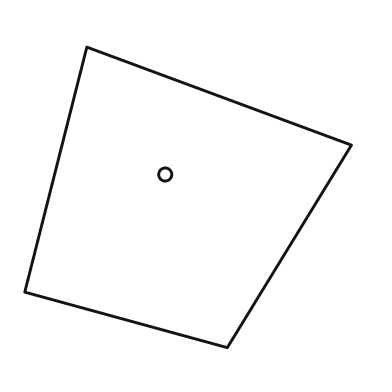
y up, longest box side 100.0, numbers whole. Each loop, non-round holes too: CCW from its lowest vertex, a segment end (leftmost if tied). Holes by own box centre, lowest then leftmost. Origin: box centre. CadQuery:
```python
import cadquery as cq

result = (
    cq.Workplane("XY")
    .moveTo(12.0, -46.0)
    .lineTo(50.0, 16.0)
    .lineTo(-31.0, 46.0)
    .lineTo(-50.0, -29.0)
    .close()
    .moveTo(-7.0, 7.0)
    .circle(2.0)
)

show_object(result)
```